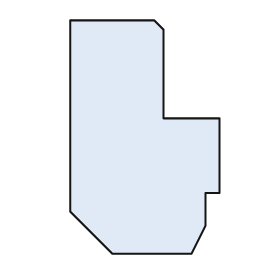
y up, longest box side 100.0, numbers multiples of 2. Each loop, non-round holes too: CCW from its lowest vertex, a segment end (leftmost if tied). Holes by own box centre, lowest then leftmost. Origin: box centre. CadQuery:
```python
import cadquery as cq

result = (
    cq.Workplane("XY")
    .moveTo(-14.0, -50.0)
    .lineTo(20.0, -50.0)
    .lineTo(26.0, -38.0)
    .lineTo(26.0, -24.0)
    .lineTo(32.0, -24.0)
    .lineTo(32.0, 8.0)
    .lineTo(8.0, 8.0)
    .lineTo(8.0, 46.0)
    .lineTo(4.0, 50.0)
    .lineTo(-32.0, 50.0)
    .lineTo(-32.0, -32.0)
    .close()
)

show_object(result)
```